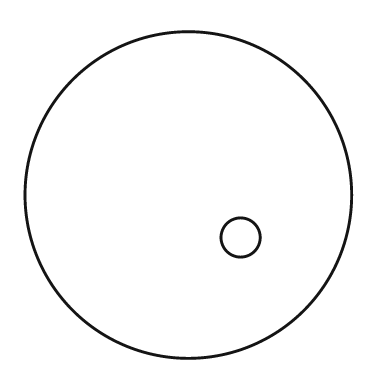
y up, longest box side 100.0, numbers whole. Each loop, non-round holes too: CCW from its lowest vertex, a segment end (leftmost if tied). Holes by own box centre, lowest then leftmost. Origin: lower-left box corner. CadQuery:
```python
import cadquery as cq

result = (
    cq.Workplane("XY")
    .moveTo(50.0, 50.0)
    .circle(50.0)
    .moveTo(66.0, 37.0)
    .circle(6.0)
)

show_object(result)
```